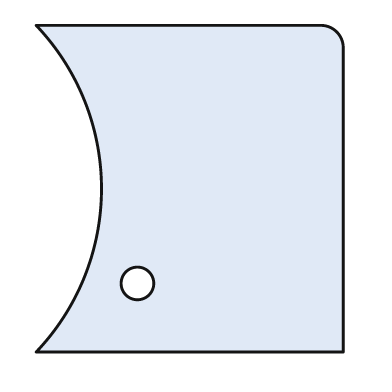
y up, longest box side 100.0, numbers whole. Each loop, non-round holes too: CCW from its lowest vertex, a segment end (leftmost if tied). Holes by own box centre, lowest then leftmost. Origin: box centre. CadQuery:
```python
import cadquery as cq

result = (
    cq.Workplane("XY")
    .moveTo(-47.0, -50.0)
    .lineTo(47.0, -50.0)
    .lineTo(47.0, 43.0)
    .threePointArc((45.0, 48.0), (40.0, 50.0))
    .lineTo(-47.0, 50.0)
    .threePointArc((-27.0, 0.0), (-47.0, -50.0))
    .close()
    .moveTo(-16.0, -29.0)
    .circle(5.0)
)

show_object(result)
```